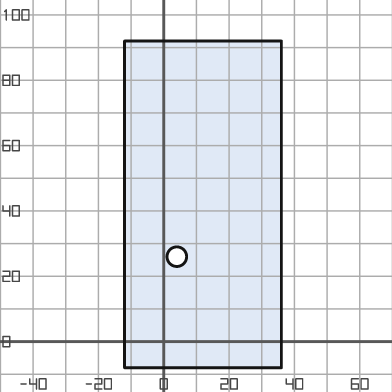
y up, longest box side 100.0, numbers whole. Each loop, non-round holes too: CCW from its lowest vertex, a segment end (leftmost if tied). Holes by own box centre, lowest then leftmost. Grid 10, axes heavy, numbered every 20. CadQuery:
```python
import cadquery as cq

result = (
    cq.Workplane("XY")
    .moveTo(-12.0, -8.0)
    .lineTo(36.0, -8.0)
    .lineTo(36.0, 92.0)
    .lineTo(-12.0, 92.0)
    .close()
    .moveTo(4.0, 26.0)
    .circle(3.0)
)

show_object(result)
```